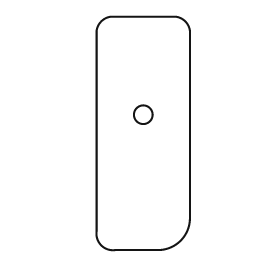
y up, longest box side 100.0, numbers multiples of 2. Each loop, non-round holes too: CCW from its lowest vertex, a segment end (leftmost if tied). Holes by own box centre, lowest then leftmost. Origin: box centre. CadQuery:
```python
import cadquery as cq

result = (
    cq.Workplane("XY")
    .moveTo(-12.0, -50.0)
    .lineTo(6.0, -50.0)
    .threePointArc((16.0, -46.0), (20.0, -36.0))
    .lineTo(20.0, 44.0)
    .threePointArc((18.0, 48.0), (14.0, 50.0))
    .lineTo(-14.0, 50.0)
    .threePointArc((-18.0, 48.0), (-20.0, 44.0))
    .lineTo(-20.0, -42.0)
    .threePointArc((-18.0, -48.0), (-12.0, -50.0))
    .close()
    .moveTo(0.0, 8.0)
    .circle(4.0)
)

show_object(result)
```